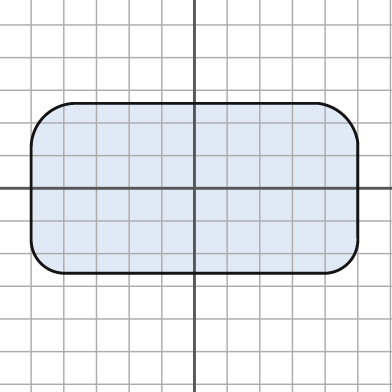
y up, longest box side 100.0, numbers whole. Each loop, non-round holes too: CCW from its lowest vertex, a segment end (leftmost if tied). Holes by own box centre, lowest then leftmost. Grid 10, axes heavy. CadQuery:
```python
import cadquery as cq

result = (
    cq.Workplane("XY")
    .moveTo(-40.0, -26.0)
    .lineTo(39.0, -26.0)
    .threePointArc((47.0, -23.0), (50.0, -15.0))
    .lineTo(50.0, 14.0)
    .threePointArc((46.0, 22.0), (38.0, 26.0))
    .lineTo(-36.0, 26.0)
    .threePointArc((-46.0, 22.0), (-50.0, 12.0))
    .lineTo(-50.0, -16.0)
    .threePointArc((-47.0, -23.0), (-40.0, -26.0))
    .close()
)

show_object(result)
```